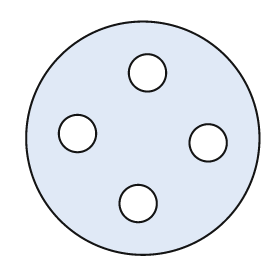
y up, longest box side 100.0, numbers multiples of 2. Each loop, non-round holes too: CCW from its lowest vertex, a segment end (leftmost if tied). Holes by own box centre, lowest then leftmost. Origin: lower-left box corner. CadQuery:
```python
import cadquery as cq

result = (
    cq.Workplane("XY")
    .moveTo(50.0, 50.0)
    .circle(50.0)
    .moveTo(48.0, 22.0)
    .circle(8.0)
    .moveTo(78.0, 48.0)
    .circle(8.0)
    .moveTo(22.0, 52.0)
    .circle(8.0)
    .moveTo(52.0, 78.0)
    .circle(8.0)
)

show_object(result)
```